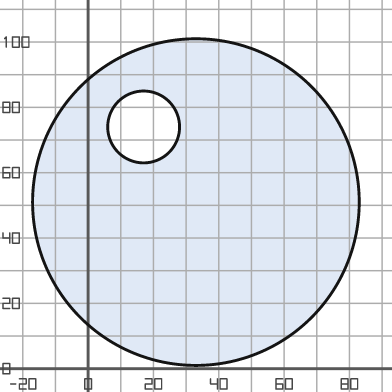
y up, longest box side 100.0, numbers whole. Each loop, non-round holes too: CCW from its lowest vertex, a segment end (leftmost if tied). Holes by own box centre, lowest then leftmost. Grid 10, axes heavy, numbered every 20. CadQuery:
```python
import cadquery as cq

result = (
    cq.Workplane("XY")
    .moveTo(33.0, 51.0)
    .circle(50.0)
    .moveTo(17.0, 74.0)
    .circle(11.0)
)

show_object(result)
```